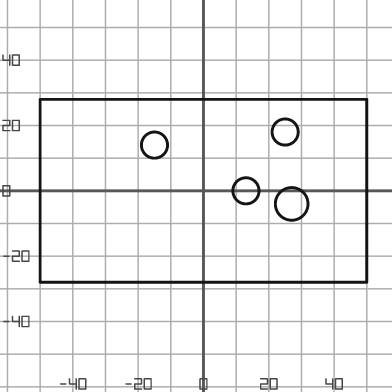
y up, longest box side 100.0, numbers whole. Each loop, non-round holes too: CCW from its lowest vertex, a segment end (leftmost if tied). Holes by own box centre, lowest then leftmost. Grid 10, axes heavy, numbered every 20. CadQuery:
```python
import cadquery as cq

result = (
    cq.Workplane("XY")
    .moveTo(-50.0, -28.0)
    .lineTo(50.0, -28.0)
    .lineTo(50.0, 28.0)
    .lineTo(-50.0, 28.0)
    .close()
    .moveTo(27.0, -4.0)
    .circle(5.0)
    .moveTo(13.0, 0.0)
    .circle(4.0)
    .moveTo(-15.0, 14.0)
    .circle(4.0)
    .moveTo(25.0, 18.0)
    .circle(4.0)
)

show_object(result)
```